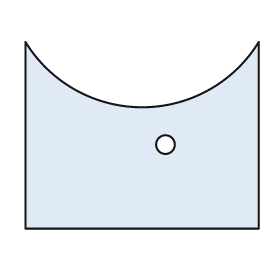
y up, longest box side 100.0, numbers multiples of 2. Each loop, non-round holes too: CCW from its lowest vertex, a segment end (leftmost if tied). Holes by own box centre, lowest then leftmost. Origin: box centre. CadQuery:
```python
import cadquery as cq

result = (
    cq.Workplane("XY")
    .moveTo(-50.0, -40.0)
    .lineTo(50.0, -40.0)
    .lineTo(50.0, 40.0)
    .threePointArc((0.0, 12.0), (-50.0, 40.0))
    .close()
    .moveTo(10.0, -4.0)
    .circle(4.0)
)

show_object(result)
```